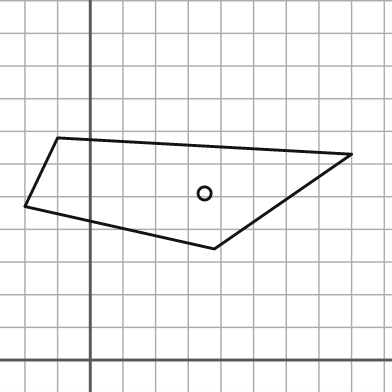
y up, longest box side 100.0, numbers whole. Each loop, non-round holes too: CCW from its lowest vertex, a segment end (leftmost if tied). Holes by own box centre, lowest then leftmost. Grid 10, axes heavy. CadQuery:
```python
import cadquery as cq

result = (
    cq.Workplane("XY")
    .moveTo(38.0, 34.0)
    .lineTo(80.0, 63.0)
    .lineTo(-10.0, 68.0)
    .lineTo(-20.0, 47.0)
    .close()
    .moveTo(35.0, 51.0)
    .circle(2.0)
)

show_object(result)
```